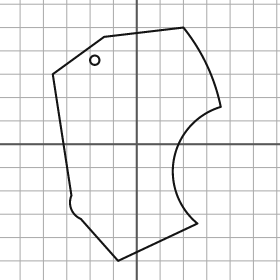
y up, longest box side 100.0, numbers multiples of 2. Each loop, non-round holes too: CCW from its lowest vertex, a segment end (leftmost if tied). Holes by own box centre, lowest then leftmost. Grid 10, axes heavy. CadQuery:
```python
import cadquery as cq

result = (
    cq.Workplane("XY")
    .moveTo(-8.0, -50.0)
    .lineTo(26.0, -34.0)
    .threePointArc((16.0, -6.0), (36.0, 16.0))
    .threePointArc((30.0, 34.0), (20.0, 50.0))
    .lineTo(-14.0, 46.0)
    .lineTo(-36.0, 30.0)
    .lineTo(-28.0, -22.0)
    .threePointArc((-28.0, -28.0), (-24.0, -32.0))
    .close()
    .moveTo(-18.0, 36.0)
    .circle(2.0)
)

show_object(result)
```